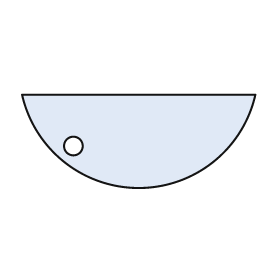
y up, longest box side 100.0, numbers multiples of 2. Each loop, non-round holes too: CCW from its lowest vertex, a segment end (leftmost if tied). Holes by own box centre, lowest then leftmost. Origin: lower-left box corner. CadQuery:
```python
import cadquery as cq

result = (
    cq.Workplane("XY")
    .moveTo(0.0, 40.0)
    .threePointArc((50.0, 0.0), (100.0, 40.0))
    .close()
    .moveTo(22.0, 18.0)
    .circle(4.0)
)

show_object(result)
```